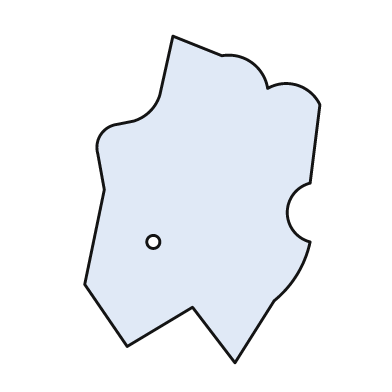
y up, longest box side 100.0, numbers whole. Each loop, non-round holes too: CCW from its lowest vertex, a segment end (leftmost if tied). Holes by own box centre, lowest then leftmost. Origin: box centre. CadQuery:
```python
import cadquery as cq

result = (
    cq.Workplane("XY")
    .moveTo(10.0, -50.0)
    .lineTo(22.0, -31.0)
    .threePointArc((29.0, -23.0), (33.0, -13.0))
    .threePointArc((26.0, -4.0), (33.0, 5.0))
    .lineTo(36.0, 29.0)
    .threePointArc((29.0, 35.0), (20.0, 34.0))
    .threePointArc((15.0, 42.0), (6.0, 44.0))
    .lineTo(-9.0, 50.0)
    .lineTo(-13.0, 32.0)
    .threePointArc((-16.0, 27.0), (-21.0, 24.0))
    .lineTo(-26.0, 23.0)
    .threePointArc((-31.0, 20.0), (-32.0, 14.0))
    .lineTo(-30.0, 3.0)
    .lineTo(-36.0, -26.0)
    .lineTo(-23.0, -45.0)
    .lineTo(-3.0, -33.0)
    .close()
    .moveTo(-15.0, -13.0)
    .circle(2.0)
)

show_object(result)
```